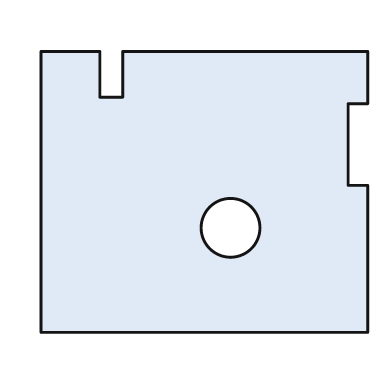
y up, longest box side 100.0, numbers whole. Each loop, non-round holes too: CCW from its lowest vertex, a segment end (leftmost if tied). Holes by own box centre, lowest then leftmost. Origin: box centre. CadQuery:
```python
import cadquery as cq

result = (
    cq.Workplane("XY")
    .moveTo(-50.0, -43.0)
    .lineTo(50.0, -43.0)
    .lineTo(50.0, 2.0)
    .lineTo(44.0, 2.0)
    .lineTo(44.0, 27.0)
    .lineTo(50.0, 27.0)
    .lineTo(50.0, 43.0)
    .lineTo(-25.0, 43.0)
    .lineTo(-25.0, 29.0)
    .lineTo(-32.0, 29.0)
    .lineTo(-32.0, 43.0)
    .lineTo(-50.0, 43.0)
    .close()
    .moveTo(8.0, -11.0)
    .circle(9.0)
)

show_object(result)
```